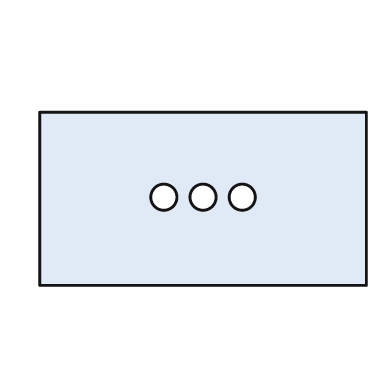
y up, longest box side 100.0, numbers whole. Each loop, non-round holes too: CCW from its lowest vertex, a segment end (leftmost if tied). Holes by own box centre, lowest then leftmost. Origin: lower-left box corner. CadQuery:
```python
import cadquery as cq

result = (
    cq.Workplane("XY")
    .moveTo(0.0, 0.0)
    .lineTo(100.0, 0.0)
    .lineTo(100.0, 53.0)
    .lineTo(0.0, 53.0)
    .close()
    .moveTo(38.0, 27.0)
    .circle(4.0)
    .moveTo(50.0, 27.0)
    .circle(4.0)
    .moveTo(62.0, 27.0)
    .circle(4.0)
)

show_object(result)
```